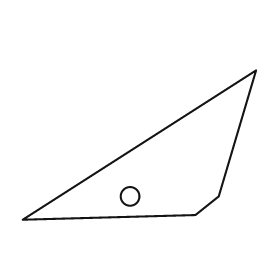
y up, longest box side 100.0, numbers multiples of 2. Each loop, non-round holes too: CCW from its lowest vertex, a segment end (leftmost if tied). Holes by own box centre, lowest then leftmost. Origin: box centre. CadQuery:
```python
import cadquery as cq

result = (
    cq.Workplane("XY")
    .moveTo(-50.0, -32.0)
    .lineTo(24.0, -30.0)
    .lineTo(34.0, -22.0)
    .lineTo(50.0, 32.0)
    .close()
    .moveTo(-4.0, -22.0)
    .circle(4.0)
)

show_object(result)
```